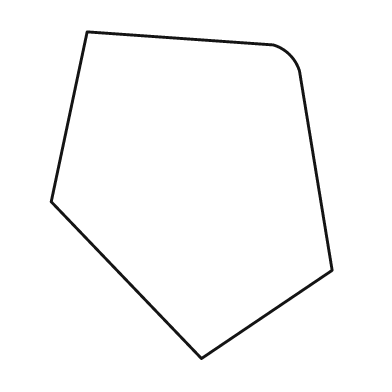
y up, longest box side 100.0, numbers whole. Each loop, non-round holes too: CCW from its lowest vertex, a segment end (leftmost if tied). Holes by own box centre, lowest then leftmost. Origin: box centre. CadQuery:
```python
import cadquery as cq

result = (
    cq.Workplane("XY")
    .moveTo(3.0, -50.0)
    .lineTo(43.0, -23.0)
    .lineTo(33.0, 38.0)
    .threePointArc((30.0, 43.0), (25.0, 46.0))
    .lineTo(-32.0, 50.0)
    .lineTo(-43.0, -2.0)
    .close()
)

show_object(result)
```